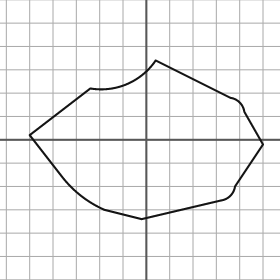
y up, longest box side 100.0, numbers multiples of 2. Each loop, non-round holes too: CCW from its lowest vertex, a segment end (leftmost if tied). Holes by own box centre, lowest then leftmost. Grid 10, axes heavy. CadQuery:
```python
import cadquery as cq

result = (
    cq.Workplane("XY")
    .moveTo(-2.0, -34.0)
    .lineTo(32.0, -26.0)
    .threePointArc((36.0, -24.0), (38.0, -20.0))
    .lineTo(50.0, -2.0)
    .lineTo(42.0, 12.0)
    .threePointArc((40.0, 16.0), (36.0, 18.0))
    .lineTo(4.0, 34.0)
    .threePointArc((-8.0, 24.0), (-24.0, 22.0))
    .lineTo(-50.0, 2.0)
    .lineTo(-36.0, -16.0)
    .threePointArc((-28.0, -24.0), (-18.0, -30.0))
    .close()
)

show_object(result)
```